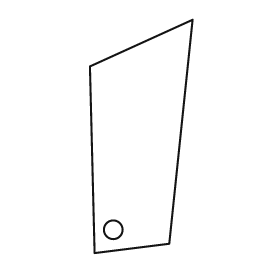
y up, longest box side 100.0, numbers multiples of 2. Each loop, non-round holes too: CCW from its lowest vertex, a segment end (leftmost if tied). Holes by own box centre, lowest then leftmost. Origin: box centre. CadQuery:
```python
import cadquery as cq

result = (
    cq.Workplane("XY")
    .moveTo(-20.0, -50.0)
    .lineTo(12.0, -46.0)
    .lineTo(22.0, 50.0)
    .lineTo(-22.0, 30.0)
    .close()
    .moveTo(-12.0, -40.0)
    .circle(4.0)
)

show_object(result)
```